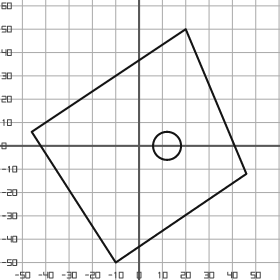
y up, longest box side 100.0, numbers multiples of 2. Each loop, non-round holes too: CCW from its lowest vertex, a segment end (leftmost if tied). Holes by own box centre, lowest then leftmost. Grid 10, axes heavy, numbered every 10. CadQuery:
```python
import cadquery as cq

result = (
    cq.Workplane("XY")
    .moveTo(-10.0, -50.0)
    .lineTo(46.0, -12.0)
    .lineTo(20.0, 50.0)
    .lineTo(-46.0, 6.0)
    .close()
    .moveTo(12.0, 0.0)
    .circle(6.0)
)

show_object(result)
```